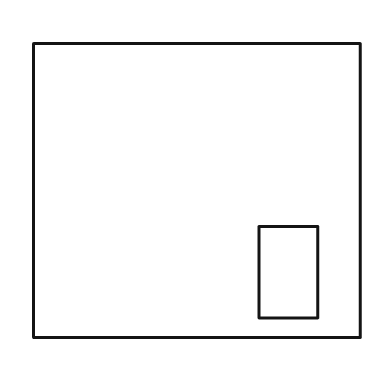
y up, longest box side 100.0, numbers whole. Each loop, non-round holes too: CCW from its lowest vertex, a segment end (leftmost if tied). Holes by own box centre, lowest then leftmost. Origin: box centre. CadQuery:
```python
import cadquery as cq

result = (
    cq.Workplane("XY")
    .moveTo(-50.0, -45.0)
    .lineTo(50.0, -45.0)
    .lineTo(50.0, 45.0)
    .lineTo(-50.0, 45.0)
    .close()
    .moveTo(19.0, -39.0)
    .lineTo(37.0, -39.0)
    .lineTo(37.0, -11.0)
    .lineTo(19.0, -11.0)
    .close()
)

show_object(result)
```